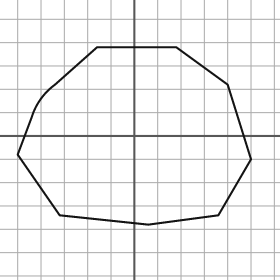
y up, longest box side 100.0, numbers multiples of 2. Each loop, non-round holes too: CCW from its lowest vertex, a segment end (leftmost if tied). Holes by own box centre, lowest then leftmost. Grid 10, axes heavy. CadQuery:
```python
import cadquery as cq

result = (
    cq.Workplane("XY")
    .moveTo(6.0, -38.0)
    .lineTo(36.0, -34.0)
    .lineTo(50.0, -10.0)
    .lineTo(40.0, 22.0)
    .lineTo(18.0, 38.0)
    .lineTo(-16.0, 38.0)
    .lineTo(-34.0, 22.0)
    .threePointArc((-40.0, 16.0), (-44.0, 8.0))
    .lineTo(-50.0, -8.0)
    .lineTo(-32.0, -34.0)
    .close()
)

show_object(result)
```